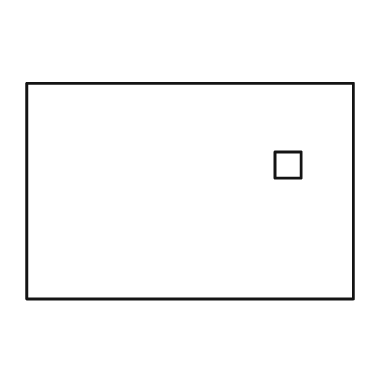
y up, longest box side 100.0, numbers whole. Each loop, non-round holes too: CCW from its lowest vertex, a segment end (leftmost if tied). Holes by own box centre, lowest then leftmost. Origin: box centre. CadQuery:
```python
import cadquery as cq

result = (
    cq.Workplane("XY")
    .moveTo(-50.0, -33.0)
    .lineTo(50.0, -33.0)
    .lineTo(50.0, 33.0)
    .lineTo(-50.0, 33.0)
    .close()
    .moveTo(26.0, 4.0)
    .lineTo(34.0, 4.0)
    .lineTo(34.0, 12.0)
    .lineTo(26.0, 12.0)
    .close()
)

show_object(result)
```